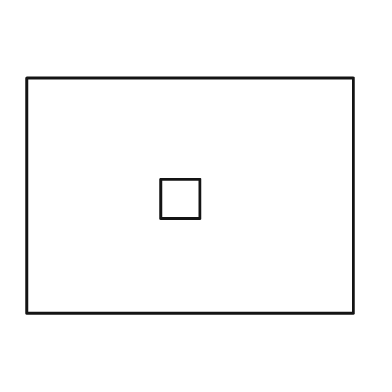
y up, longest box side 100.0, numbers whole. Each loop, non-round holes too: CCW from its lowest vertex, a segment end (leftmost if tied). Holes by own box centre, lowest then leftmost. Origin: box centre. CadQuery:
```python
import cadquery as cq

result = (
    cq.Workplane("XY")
    .moveTo(-50.0, -36.0)
    .lineTo(50.0, -36.0)
    .lineTo(50.0, 36.0)
    .lineTo(-50.0, 36.0)
    .close()
    .moveTo(-9.0, -7.0)
    .lineTo(3.0, -7.0)
    .lineTo(3.0, 5.0)
    .lineTo(-9.0, 5.0)
    .close()
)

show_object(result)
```